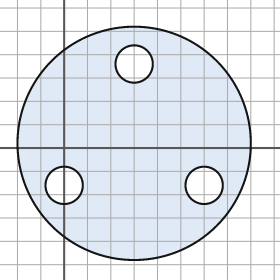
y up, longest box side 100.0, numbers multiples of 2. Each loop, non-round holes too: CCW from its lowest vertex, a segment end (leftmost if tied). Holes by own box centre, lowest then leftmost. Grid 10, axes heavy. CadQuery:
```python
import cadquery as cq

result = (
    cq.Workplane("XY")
    .moveTo(30.0, 2.0)
    .circle(50.0)
    .moveTo(0.0, -16.0)
    .circle(8.0)
    .moveTo(60.0, -16.0)
    .circle(8.0)
    .moveTo(30.0, 36.0)
    .circle(8.0)
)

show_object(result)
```